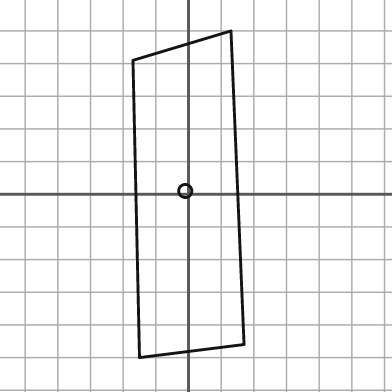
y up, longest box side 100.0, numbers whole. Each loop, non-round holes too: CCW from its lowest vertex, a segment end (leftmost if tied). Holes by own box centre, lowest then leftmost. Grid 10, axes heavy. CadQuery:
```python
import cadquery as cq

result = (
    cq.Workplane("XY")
    .moveTo(-15.0, -50.0)
    .lineTo(17.0, -46.0)
    .lineTo(13.0, 50.0)
    .lineTo(-17.0, 41.0)
    .close()
    .moveTo(-1.0, 1.0)
    .circle(2.0)
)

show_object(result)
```